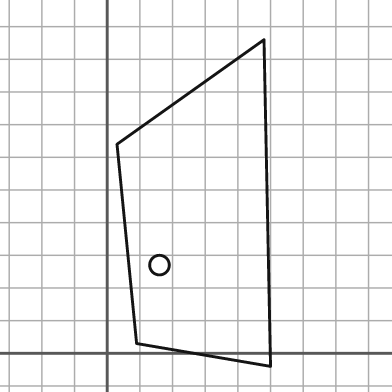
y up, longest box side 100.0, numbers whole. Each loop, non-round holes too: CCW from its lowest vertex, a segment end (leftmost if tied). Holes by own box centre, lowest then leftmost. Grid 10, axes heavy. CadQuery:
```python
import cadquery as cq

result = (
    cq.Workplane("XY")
    .moveTo(50.0, -4.0)
    .lineTo(48.0, 96.0)
    .lineTo(3.0, 64.0)
    .lineTo(9.0, 3.0)
    .close()
    .moveTo(16.0, 27.0)
    .circle(3.0)
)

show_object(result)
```